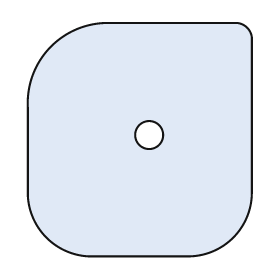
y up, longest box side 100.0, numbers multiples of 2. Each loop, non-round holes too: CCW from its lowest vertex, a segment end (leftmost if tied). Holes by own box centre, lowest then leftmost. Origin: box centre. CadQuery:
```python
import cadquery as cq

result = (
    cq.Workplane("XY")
    .moveTo(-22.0, -50.0)
    .lineTo(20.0, -50.0)
    .threePointArc((40.0, -42.0), (48.0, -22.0))
    .lineTo(48.0, 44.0)
    .threePointArc((46.0, 48.0), (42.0, 50.0))
    .lineTo(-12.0, 50.0)
    .threePointArc((-38.0, 40.0), (-48.0, 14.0))
    .lineTo(-48.0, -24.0)
    .threePointArc((-40.0, -42.0), (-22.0, -50.0))
    .close()
    .moveTo(4.0, 2.0)
    .circle(6.0)
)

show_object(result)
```